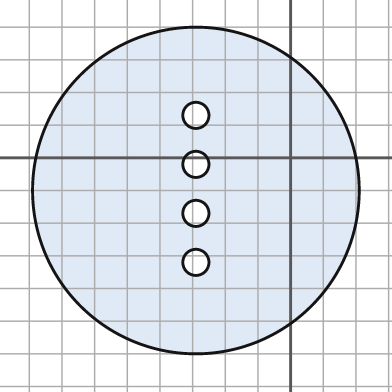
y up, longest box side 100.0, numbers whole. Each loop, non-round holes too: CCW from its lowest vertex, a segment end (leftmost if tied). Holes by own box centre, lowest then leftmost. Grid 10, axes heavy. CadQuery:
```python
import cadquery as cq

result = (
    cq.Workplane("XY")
    .moveTo(-29.0, -10.0)
    .circle(50.0)
    .moveTo(-29.0, -32.0)
    .circle(4.0)
    .moveTo(-29.0, -17.0)
    .circle(4.0)
    .moveTo(-29.0, -2.0)
    .circle(4.0)
    .moveTo(-29.0, 13.0)
    .circle(4.0)
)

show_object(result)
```